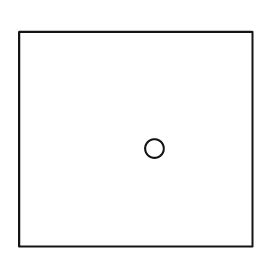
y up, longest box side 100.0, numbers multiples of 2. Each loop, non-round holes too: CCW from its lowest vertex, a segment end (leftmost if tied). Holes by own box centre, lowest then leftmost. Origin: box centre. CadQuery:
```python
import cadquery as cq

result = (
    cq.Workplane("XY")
    .moveTo(-50.0, -46.0)
    .lineTo(50.0, -46.0)
    .lineTo(50.0, 46.0)
    .lineTo(-50.0, 46.0)
    .close()
    .moveTo(8.0, -4.0)
    .circle(4.0)
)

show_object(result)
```